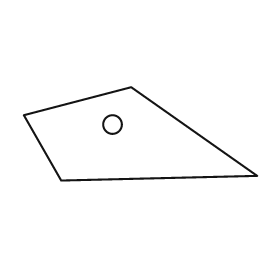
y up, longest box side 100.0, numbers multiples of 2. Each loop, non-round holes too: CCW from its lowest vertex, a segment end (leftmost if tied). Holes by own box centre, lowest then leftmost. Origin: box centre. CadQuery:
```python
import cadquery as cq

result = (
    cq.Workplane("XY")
    .moveTo(-34.0, -20.0)
    .lineTo(50.0, -18.0)
    .lineTo(-4.0, 20.0)
    .lineTo(-50.0, 8.0)
    .close()
    .moveTo(-12.0, 4.0)
    .circle(4.0)
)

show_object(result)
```